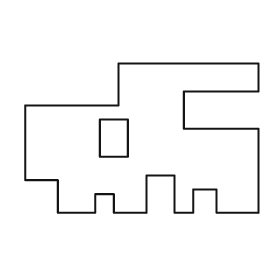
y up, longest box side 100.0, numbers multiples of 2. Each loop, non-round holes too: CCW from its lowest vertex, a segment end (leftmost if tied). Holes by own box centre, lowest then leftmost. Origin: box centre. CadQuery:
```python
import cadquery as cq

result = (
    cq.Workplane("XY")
    .moveTo(-36.0, -32.0)
    .lineTo(-20.0, -32.0)
    .lineTo(-20.0, -24.0)
    .lineTo(-12.0, -24.0)
    .lineTo(-12.0, -32.0)
    .lineTo(2.0, -32.0)
    .lineTo(2.0, -16.0)
    .lineTo(14.0, -16.0)
    .lineTo(14.0, -32.0)
    .lineTo(22.0, -32.0)
    .lineTo(22.0, -22.0)
    .lineTo(32.0, -22.0)
    .lineTo(32.0, -32.0)
    .lineTo(50.0, -32.0)
    .lineTo(50.0, 4.0)
    .lineTo(18.0, 4.0)
    .lineTo(18.0, 20.0)
    .lineTo(50.0, 20.0)
    .lineTo(50.0, 32.0)
    .lineTo(-10.0, 32.0)
    .lineTo(-10.0, 14.0)
    .lineTo(-50.0, 14.0)
    .lineTo(-50.0, -18.0)
    .lineTo(-36.0, -18.0)
    .close()
    .moveTo(-18.0, -8.0)
    .lineTo(-6.0, -8.0)
    .lineTo(-6.0, 8.0)
    .lineTo(-18.0, 8.0)
    .close()
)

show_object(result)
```